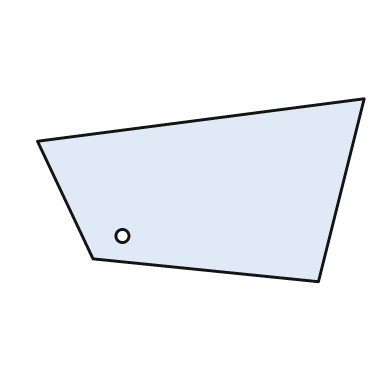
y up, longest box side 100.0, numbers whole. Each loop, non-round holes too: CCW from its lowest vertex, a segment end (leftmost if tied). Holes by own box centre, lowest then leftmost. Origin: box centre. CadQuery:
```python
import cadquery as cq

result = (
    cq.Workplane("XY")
    .moveTo(36.0, -28.0)
    .lineTo(50.0, 28.0)
    .lineTo(-50.0, 15.0)
    .lineTo(-33.0, -21.0)
    .close()
    .moveTo(-24.0, -14.0)
    .circle(2.0)
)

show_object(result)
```